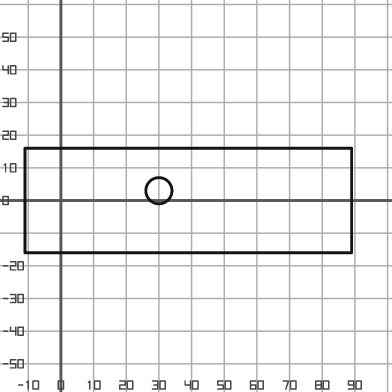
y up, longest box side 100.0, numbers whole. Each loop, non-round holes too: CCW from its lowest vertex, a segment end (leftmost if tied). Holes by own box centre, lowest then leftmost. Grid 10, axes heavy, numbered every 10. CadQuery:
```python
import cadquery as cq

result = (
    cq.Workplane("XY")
    .moveTo(-11.0, -16.0)
    .lineTo(89.0, -16.0)
    .lineTo(89.0, 16.0)
    .lineTo(-11.0, 16.0)
    .close()
    .moveTo(30.0, 3.0)
    .circle(4.0)
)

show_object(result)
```